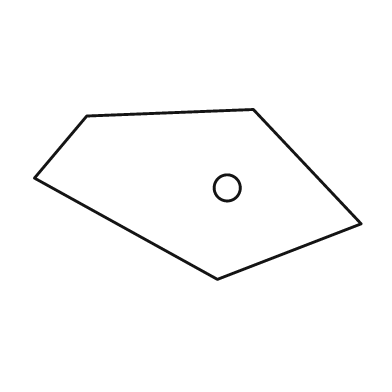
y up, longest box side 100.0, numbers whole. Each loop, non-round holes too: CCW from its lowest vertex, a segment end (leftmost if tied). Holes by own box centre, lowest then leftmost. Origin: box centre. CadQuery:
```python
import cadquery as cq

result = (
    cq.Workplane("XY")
    .moveTo(6.0, -26.0)
    .lineTo(50.0, -9.0)
    .lineTo(17.0, 26.0)
    .lineTo(-34.0, 24.0)
    .lineTo(-50.0, 5.0)
    .close()
    .moveTo(9.0, 2.0)
    .circle(4.0)
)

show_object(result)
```